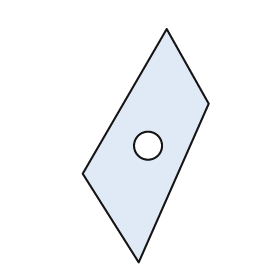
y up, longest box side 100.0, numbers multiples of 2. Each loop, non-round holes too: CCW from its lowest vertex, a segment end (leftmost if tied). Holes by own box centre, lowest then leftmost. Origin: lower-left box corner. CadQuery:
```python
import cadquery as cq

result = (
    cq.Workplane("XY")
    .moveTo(24.0, 0.0)
    .lineTo(54.0, 68.0)
    .lineTo(36.0, 100.0)
    .lineTo(0.0, 38.0)
    .close()
    .moveTo(28.0, 50.0)
    .circle(6.0)
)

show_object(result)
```